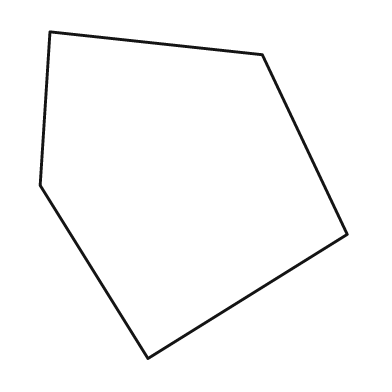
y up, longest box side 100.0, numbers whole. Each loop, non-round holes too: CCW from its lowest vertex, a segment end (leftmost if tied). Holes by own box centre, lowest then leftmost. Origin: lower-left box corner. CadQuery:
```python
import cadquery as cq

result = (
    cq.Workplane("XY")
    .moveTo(33.0, 0.0)
    .lineTo(94.0, 38.0)
    .lineTo(68.0, 93.0)
    .lineTo(3.0, 100.0)
    .lineTo(0.0, 53.0)
    .close()
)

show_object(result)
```